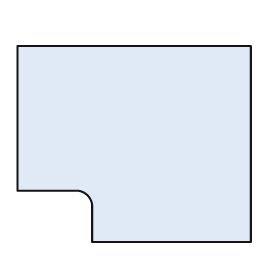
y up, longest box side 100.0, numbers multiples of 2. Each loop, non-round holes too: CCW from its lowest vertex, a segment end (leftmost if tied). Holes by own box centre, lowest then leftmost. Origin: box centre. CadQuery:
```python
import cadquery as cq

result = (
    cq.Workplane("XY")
    .moveTo(-18.0, -42.0)
    .lineTo(50.0, -42.0)
    .lineTo(50.0, 42.0)
    .lineTo(-50.0, 42.0)
    .lineTo(-50.0, -20.0)
    .lineTo(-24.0, -20.0)
    .threePointArc((-20.0, -22.0), (-18.0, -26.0))
    .close()
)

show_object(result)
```